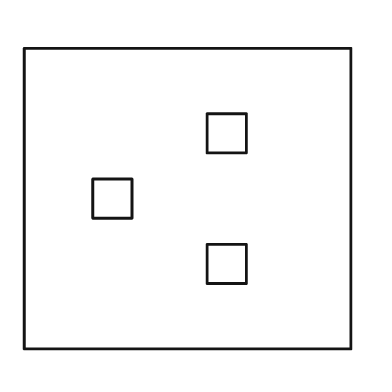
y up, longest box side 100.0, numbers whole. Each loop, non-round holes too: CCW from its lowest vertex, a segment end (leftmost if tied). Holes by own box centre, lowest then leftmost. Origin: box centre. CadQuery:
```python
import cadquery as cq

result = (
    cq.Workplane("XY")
    .moveTo(-50.0, -46.0)
    .lineTo(50.0, -46.0)
    .lineTo(50.0, 46.0)
    .lineTo(-50.0, 46.0)
    .close()
    .moveTo(6.0, -26.0)
    .lineTo(18.0, -26.0)
    .lineTo(18.0, -14.0)
    .lineTo(6.0, -14.0)
    .close()
    .moveTo(-29.0, -6.0)
    .lineTo(-17.0, -6.0)
    .lineTo(-17.0, 6.0)
    .lineTo(-29.0, 6.0)
    .close()
    .moveTo(6.0, 14.0)
    .lineTo(18.0, 14.0)
    .lineTo(18.0, 26.0)
    .lineTo(6.0, 26.0)
    .close()
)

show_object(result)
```